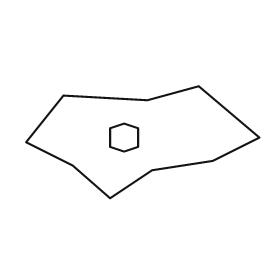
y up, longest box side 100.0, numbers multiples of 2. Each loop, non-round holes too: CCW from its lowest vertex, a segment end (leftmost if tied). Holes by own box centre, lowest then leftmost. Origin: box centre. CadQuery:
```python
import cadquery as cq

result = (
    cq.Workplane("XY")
    .moveTo(-14.0, -24.0)
    .lineTo(4.0, -12.0)
    .lineTo(30.0, -8.0)
    .lineTo(50.0, 2.0)
    .lineTo(24.0, 24.0)
    .lineTo(2.0, 18.0)
    .lineTo(-34.0, 20.0)
    .lineTo(-50.0, 0.0)
    .lineTo(-30.0, -10.0)
    .close()
    .moveTo(-8.0, -4.0)
    .lineTo(-2.0, -2.0)
    .lineTo(-2.0, 6.0)
    .lineTo(-8.0, 8.0)
    .lineTo(-14.0, 6.0)
    .lineTo(-14.0, -2.0)
    .close()
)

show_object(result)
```